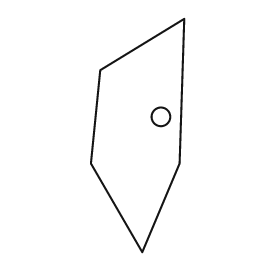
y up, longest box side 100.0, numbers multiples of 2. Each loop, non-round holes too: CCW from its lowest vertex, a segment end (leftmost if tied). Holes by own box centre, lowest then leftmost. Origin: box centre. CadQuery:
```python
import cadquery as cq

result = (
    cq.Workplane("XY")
    .moveTo(2.0, -50.0)
    .lineTo(18.0, -12.0)
    .lineTo(20.0, 50.0)
    .lineTo(-16.0, 28.0)
    .lineTo(-20.0, -12.0)
    .close()
    .moveTo(10.0, 8.0)
    .circle(4.0)
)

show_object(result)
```